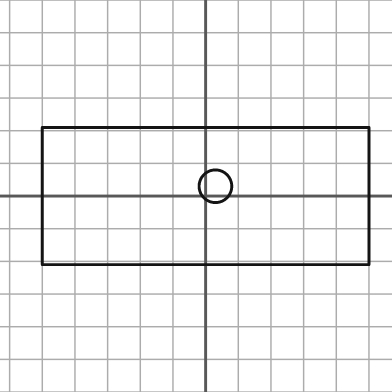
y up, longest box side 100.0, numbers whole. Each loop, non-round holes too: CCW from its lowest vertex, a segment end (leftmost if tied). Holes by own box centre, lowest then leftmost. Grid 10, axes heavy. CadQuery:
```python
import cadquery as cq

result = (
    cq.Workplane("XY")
    .moveTo(-50.0, -21.0)
    .lineTo(50.0, -21.0)
    .lineTo(50.0, 21.0)
    .lineTo(-50.0, 21.0)
    .close()
    .moveTo(3.0, 3.0)
    .circle(5.0)
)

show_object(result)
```